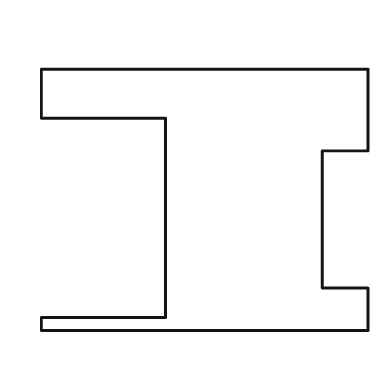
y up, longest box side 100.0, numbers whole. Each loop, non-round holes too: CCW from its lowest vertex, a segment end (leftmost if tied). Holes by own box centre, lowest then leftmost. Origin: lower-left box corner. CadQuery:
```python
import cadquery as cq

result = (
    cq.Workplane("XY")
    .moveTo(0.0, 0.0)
    .lineTo(100.0, 0.0)
    .lineTo(100.0, 13.0)
    .lineTo(86.0, 13.0)
    .lineTo(86.0, 55.0)
    .lineTo(100.0, 55.0)
    .lineTo(100.0, 80.0)
    .lineTo(0.0, 80.0)
    .lineTo(0.0, 65.0)
    .lineTo(38.0, 65.0)
    .lineTo(38.0, 4.0)
    .lineTo(0.0, 4.0)
    .close()
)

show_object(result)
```